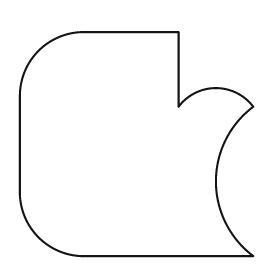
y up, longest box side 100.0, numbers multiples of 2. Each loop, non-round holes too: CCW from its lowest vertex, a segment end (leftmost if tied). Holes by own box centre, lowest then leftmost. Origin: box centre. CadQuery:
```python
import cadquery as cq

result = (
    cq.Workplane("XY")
    .moveTo(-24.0, -48.0)
    .lineTo(50.0, -48.0)
    .threePointArc((34.0, -16.0), (50.0, 16.0))
    .threePointArc((34.0, 24.0), (18.0, 16.0))
    .lineTo(18.0, 48.0)
    .lineTo(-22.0, 48.0)
    .threePointArc((-42.0, 40.0), (-50.0, 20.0))
    .lineTo(-50.0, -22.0)
    .threePointArc((-42.0, -40.0), (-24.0, -48.0))
    .close()
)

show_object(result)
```